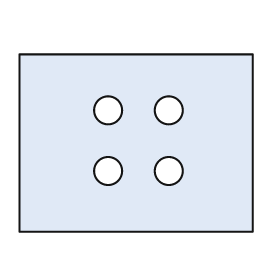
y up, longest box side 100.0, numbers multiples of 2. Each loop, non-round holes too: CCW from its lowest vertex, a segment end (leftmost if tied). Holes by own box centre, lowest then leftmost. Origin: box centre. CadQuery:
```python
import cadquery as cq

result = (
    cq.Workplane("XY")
    .moveTo(-50.0, -38.0)
    .lineTo(50.0, -38.0)
    .lineTo(50.0, 38.0)
    .lineTo(-50.0, 38.0)
    .close()
    .moveTo(-12.0, -12.0)
    .circle(6.0)
    .moveTo(14.0, -12.0)
    .circle(6.0)
    .moveTo(-12.0, 14.0)
    .circle(6.0)
    .moveTo(14.0, 14.0)
    .circle(6.0)
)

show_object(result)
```